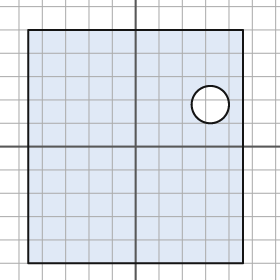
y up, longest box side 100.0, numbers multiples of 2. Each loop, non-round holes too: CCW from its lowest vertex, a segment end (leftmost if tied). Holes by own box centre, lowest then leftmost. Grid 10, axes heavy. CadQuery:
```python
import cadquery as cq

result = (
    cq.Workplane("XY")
    .moveTo(-46.0, -50.0)
    .lineTo(46.0, -50.0)
    .lineTo(46.0, 50.0)
    .lineTo(-46.0, 50.0)
    .close()
    .moveTo(32.0, 18.0)
    .circle(8.0)
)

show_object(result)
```